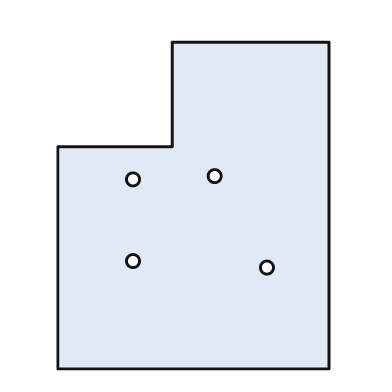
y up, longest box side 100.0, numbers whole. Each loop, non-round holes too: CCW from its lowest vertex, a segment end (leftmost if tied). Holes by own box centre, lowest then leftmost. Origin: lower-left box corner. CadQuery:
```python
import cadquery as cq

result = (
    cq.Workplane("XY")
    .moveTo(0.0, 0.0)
    .lineTo(83.0, 0.0)
    .lineTo(83.0, 100.0)
    .lineTo(35.0, 100.0)
    .lineTo(35.0, 68.0)
    .lineTo(0.0, 68.0)
    .close()
    .moveTo(64.0, 31.0)
    .circle(2.0)
    .moveTo(23.0, 33.0)
    .circle(2.0)
    .moveTo(23.0, 58.0)
    .circle(2.0)
    .moveTo(48.0, 59.0)
    .circle(2.0)
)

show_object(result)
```